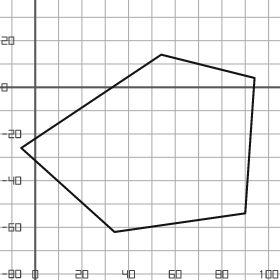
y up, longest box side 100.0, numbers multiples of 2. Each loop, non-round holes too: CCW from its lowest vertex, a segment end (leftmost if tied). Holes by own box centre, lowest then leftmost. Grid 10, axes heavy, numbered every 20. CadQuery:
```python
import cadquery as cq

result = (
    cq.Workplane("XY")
    .moveTo(34.0, -62.0)
    .lineTo(90.0, -54.0)
    .lineTo(94.0, 4.0)
    .lineTo(54.0, 14.0)
    .lineTo(-6.0, -26.0)
    .close()
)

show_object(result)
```